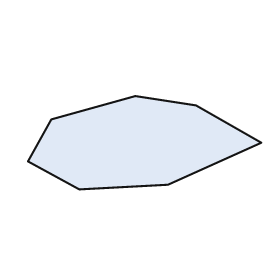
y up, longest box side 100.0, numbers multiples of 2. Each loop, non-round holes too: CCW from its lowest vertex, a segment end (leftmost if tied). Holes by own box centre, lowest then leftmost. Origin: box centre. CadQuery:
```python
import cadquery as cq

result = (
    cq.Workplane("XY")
    .moveTo(-28.0, -20.0)
    .lineTo(10.0, -18.0)
    .lineTo(50.0, 0.0)
    .lineTo(22.0, 16.0)
    .lineTo(-4.0, 20.0)
    .lineTo(-40.0, 10.0)
    .lineTo(-50.0, -8.0)
    .close()
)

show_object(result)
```